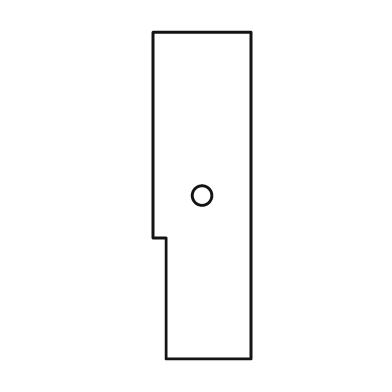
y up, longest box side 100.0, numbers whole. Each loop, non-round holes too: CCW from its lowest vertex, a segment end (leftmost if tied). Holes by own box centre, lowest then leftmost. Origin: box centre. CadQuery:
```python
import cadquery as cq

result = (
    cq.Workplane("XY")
    .moveTo(-11.0, -50.0)
    .lineTo(15.0, -50.0)
    .lineTo(15.0, 50.0)
    .lineTo(-15.0, 50.0)
    .lineTo(-15.0, -13.0)
    .lineTo(-11.0, -13.0)
    .close()
    .moveTo(0.0, 0.0)
    .circle(3.0)
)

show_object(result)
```